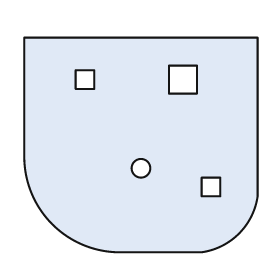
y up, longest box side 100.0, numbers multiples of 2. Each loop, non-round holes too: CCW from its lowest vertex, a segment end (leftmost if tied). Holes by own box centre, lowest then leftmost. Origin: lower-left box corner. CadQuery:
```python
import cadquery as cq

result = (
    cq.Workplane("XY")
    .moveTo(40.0, 0.0)
    .lineTo(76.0, 0.0)
    .threePointArc((92.0, 8.0), (100.0, 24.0))
    .lineTo(100.0, 92.0)
    .lineTo(0.0, 92.0)
    .lineTo(0.0, 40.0)
    .threePointArc((12.0, 12.0), (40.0, 0.0))
    .close()
    .moveTo(76.0, 24.0)
    .lineTo(84.0, 24.0)
    .lineTo(84.0, 32.0)
    .lineTo(76.0, 32.0)
    .close()
    .moveTo(50.0, 36.0)
    .circle(4.0)
    .moveTo(22.0, 70.0)
    .lineTo(30.0, 70.0)
    .lineTo(30.0, 78.0)
    .lineTo(22.0, 78.0)
    .close()
    .moveTo(62.0, 68.0)
    .lineTo(74.0, 68.0)
    .lineTo(74.0, 80.0)
    .lineTo(62.0, 80.0)
    .close()
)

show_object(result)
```